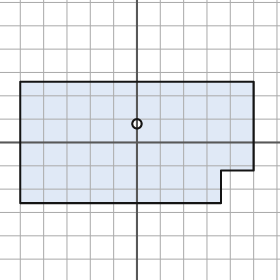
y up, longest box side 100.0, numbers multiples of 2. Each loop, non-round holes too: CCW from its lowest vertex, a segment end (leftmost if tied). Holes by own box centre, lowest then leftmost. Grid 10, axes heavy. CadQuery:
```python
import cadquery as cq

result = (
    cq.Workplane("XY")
    .moveTo(-50.0, -26.0)
    .lineTo(36.0, -26.0)
    .lineTo(36.0, -12.0)
    .lineTo(50.0, -12.0)
    .lineTo(50.0, 26.0)
    .lineTo(-50.0, 26.0)
    .close()
    .moveTo(0.0, 8.0)
    .circle(2.0)
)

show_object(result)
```